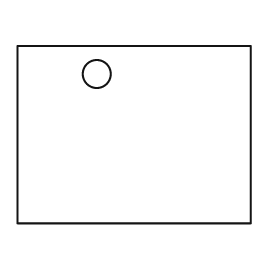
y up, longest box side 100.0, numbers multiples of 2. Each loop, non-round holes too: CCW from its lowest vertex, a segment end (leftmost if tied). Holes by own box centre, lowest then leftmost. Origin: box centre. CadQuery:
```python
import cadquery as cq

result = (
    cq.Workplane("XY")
    .moveTo(-50.0, -38.0)
    .lineTo(50.0, -38.0)
    .lineTo(50.0, 38.0)
    .lineTo(-50.0, 38.0)
    .close()
    .moveTo(-16.0, 26.0)
    .circle(6.0)
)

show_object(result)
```